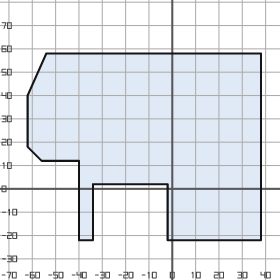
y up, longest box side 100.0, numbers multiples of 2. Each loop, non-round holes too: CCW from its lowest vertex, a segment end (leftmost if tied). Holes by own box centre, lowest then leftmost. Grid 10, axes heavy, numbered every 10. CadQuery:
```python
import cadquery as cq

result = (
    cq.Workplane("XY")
    .moveTo(-40.0, -22.0)
    .lineTo(-34.0, -22.0)
    .lineTo(-34.0, 2.0)
    .lineTo(-2.0, 2.0)
    .lineTo(-2.0, -22.0)
    .lineTo(38.0, -22.0)
    .lineTo(38.0, 58.0)
    .lineTo(-54.0, 58.0)
    .lineTo(-62.0, 40.0)
    .lineTo(-62.0, 18.0)
    .lineTo(-56.0, 12.0)
    .lineTo(-40.0, 12.0)
    .close()
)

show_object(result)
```